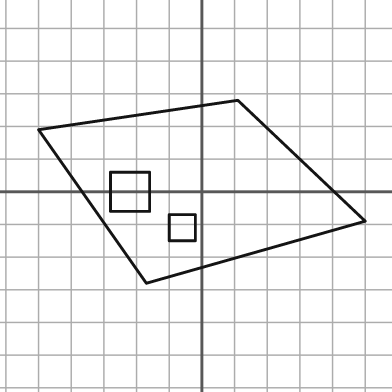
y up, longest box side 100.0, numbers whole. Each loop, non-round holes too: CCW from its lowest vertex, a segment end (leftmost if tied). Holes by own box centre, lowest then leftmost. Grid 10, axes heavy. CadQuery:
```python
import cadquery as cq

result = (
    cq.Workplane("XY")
    .moveTo(-17.0, -28.0)
    .lineTo(50.0, -9.0)
    .lineTo(11.0, 28.0)
    .lineTo(-50.0, 19.0)
    .close()
    .moveTo(-10.0, -15.0)
    .lineTo(-2.0, -15.0)
    .lineTo(-2.0, -7.0)
    .lineTo(-10.0, -7.0)
    .close()
    .moveTo(-28.0, -6.0)
    .lineTo(-16.0, -6.0)
    .lineTo(-16.0, 6.0)
    .lineTo(-28.0, 6.0)
    .close()
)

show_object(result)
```